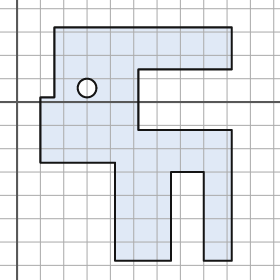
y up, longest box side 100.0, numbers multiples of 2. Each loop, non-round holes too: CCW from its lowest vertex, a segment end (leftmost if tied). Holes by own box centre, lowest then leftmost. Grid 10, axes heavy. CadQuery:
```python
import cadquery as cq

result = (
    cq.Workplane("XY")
    .moveTo(42.0, -68.0)
    .lineTo(66.0, -68.0)
    .lineTo(66.0, -30.0)
    .lineTo(80.0, -30.0)
    .lineTo(80.0, -68.0)
    .lineTo(92.0, -68.0)
    .lineTo(92.0, -12.0)
    .lineTo(52.0, -12.0)
    .lineTo(52.0, 14.0)
    .lineTo(92.0, 14.0)
    .lineTo(92.0, 32.0)
    .lineTo(16.0, 32.0)
    .lineTo(16.0, 2.0)
    .lineTo(10.0, 2.0)
    .lineTo(10.0, -26.0)
    .lineTo(42.0, -26.0)
    .close()
    .moveTo(30.0, 6.0)
    .circle(4.0)
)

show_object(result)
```